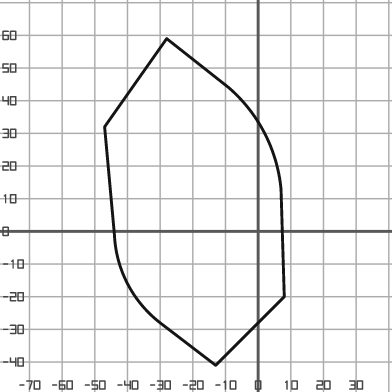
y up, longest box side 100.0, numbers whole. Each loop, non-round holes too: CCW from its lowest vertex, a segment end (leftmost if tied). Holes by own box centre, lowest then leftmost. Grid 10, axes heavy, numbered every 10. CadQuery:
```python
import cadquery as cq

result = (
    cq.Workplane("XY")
    .moveTo(-13.0, -41.0)
    .lineTo(8.0, -20.0)
    .lineTo(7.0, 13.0)
    .threePointArc((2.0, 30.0), (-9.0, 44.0))
    .lineTo(-28.0, 59.0)
    .lineTo(-47.0, 32.0)
    .lineTo(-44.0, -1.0)
    .threePointArc((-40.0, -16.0), (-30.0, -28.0))
    .close()
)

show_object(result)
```